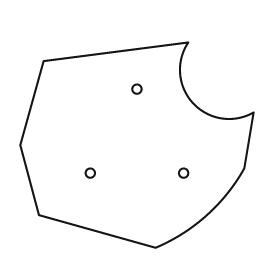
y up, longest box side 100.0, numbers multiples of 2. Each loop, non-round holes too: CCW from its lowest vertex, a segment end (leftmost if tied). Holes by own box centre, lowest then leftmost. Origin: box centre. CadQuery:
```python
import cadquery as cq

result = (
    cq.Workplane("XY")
    .moveTo(8.0, -44.0)
    .threePointArc((30.0, -30.0), (46.0, -10.0))
    .lineTo(50.0, 14.0)
    .threePointArc((24.0, 18.0), (22.0, 44.0))
    .lineTo(-40.0, 36.0)
    .lineTo(-50.0, 0.0)
    .lineTo(-42.0, -30.0)
    .close()
    .moveTo(-20.0, -12.0)
    .circle(2.0)
    .moveTo(20.0, -12.0)
    .circle(2.0)
    .moveTo(0.0, 24.0)
    .circle(2.0)
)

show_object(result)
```